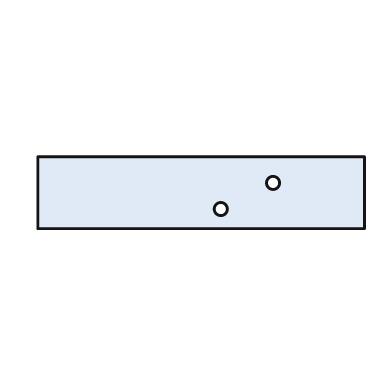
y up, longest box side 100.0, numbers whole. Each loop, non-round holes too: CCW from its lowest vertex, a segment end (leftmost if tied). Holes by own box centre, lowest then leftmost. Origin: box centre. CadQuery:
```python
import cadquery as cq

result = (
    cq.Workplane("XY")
    .moveTo(-50.0, -11.0)
    .lineTo(50.0, -11.0)
    .lineTo(50.0, 11.0)
    .lineTo(-50.0, 11.0)
    .close()
    .moveTo(6.0, -5.0)
    .circle(2.0)
    .moveTo(22.0, 3.0)
    .circle(2.0)
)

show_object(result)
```